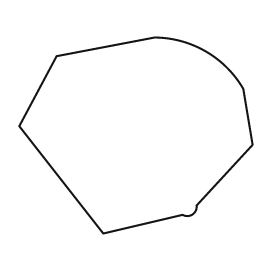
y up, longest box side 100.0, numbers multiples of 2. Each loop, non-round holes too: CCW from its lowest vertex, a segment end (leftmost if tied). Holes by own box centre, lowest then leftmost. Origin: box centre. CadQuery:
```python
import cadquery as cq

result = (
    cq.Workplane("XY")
    .moveTo(-14.0, -42.0)
    .lineTo(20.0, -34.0)
    .threePointArc((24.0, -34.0), (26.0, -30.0))
    .lineTo(50.0, -4.0)
    .lineTo(46.0, 20.0)
    .threePointArc((30.0, 36.0), (8.0, 42.0))
    .lineTo(-34.0, 34.0)
    .lineTo(-50.0, 4.0)
    .close()
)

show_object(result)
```